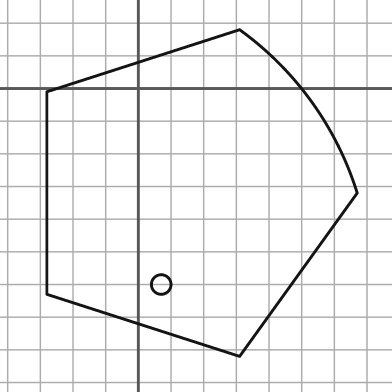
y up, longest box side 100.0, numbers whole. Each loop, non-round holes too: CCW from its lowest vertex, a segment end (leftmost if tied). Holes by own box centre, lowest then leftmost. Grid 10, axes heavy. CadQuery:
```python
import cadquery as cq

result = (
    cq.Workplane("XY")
    .moveTo(31.0, -82.0)
    .lineTo(67.0, -32.0)
    .threePointArc((53.0, -4.0), (31.0, 18.0))
    .lineTo(-28.0, -1.0)
    .lineTo(-28.0, -63.0)
    .close()
    .moveTo(7.0, -60.0)
    .circle(3.0)
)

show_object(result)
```